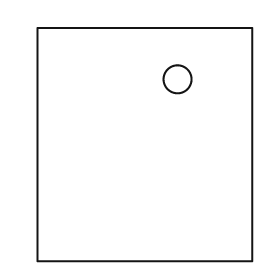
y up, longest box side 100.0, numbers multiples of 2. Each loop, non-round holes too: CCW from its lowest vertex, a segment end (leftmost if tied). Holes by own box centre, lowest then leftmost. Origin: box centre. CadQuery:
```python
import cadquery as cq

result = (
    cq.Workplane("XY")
    .moveTo(-46.0, -50.0)
    .lineTo(46.0, -50.0)
    .lineTo(46.0, 50.0)
    .lineTo(-46.0, 50.0)
    .close()
    .moveTo(14.0, 28.0)
    .circle(6.0)
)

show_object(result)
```